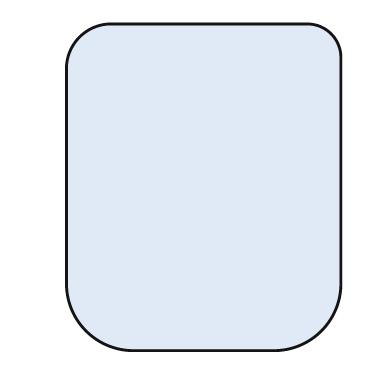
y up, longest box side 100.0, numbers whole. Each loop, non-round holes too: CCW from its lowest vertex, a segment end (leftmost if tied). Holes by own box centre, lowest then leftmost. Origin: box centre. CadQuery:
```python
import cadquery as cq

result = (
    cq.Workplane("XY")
    .moveTo(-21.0, -50.0)
    .lineTo(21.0, -50.0)
    .threePointArc((36.0, -44.0), (42.0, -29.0))
    .lineTo(42.0, 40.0)
    .threePointArc((39.0, 47.0), (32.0, 50.0))
    .lineTo(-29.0, 50.0)
    .threePointArc((-38.0, 46.0), (-42.0, 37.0))
    .lineTo(-42.0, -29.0)
    .threePointArc((-36.0, -44.0), (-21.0, -50.0))
    .close()
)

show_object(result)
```